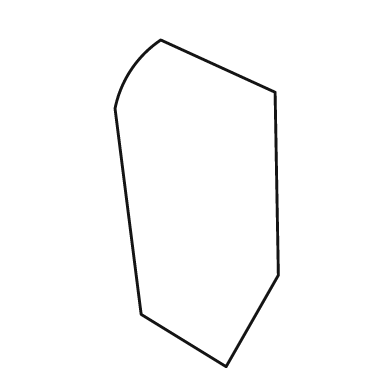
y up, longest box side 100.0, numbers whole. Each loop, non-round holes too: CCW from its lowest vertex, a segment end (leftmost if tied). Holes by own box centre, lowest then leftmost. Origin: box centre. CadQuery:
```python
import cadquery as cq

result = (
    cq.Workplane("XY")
    .moveTo(9.0, -50.0)
    .lineTo(25.0, -22.0)
    .lineTo(24.0, 34.0)
    .lineTo(-11.0, 50.0)
    .threePointArc((-20.0, 41.0), (-25.0, 29.0))
    .lineTo(-17.0, -34.0)
    .close()
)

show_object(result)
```